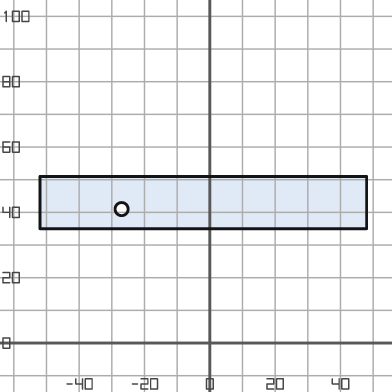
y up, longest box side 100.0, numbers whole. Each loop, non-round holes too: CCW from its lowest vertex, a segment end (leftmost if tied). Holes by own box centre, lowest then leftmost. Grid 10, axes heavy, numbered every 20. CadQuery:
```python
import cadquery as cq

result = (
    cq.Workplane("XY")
    .moveTo(-52.0, 35.0)
    .lineTo(48.0, 35.0)
    .lineTo(48.0, 51.0)
    .lineTo(-52.0, 51.0)
    .close()
    .moveTo(-27.0, 41.0)
    .circle(2.0)
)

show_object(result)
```